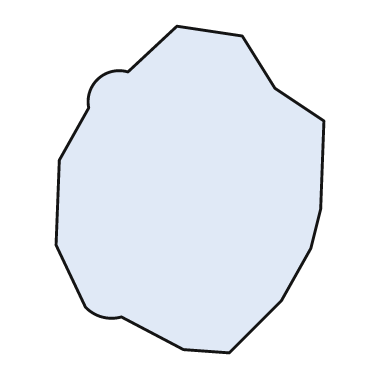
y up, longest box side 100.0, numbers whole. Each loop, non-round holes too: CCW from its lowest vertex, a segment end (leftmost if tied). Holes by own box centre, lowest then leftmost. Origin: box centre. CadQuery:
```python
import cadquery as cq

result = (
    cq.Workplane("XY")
    .moveTo(12.0, -50.0)
    .lineTo(28.0, -34.0)
    .lineTo(37.0, -18.0)
    .lineTo(40.0, -6.0)
    .lineTo(41.0, 21.0)
    .lineTo(26.0, 31.0)
    .lineTo(16.0, 47.0)
    .lineTo(-4.0, 50.0)
    .lineTo(-19.0, 36.0)
    .threePointArc((-28.0, 34.0), (-31.0, 25.0))
    .lineTo(-40.0, 9.0)
    .lineTo(-41.0, -17.0)
    .lineTo(-32.0, -36.0)
    .threePointArc((-27.0, -39.0), (-21.0, -39.0))
    .lineTo(-2.0, -49.0)
    .close()
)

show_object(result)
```